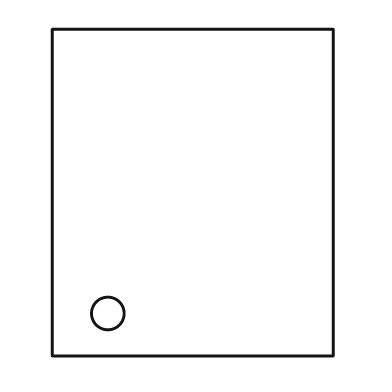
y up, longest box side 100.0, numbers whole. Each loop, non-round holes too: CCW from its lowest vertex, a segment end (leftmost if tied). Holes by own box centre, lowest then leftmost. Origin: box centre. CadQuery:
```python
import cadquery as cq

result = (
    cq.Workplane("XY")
    .moveTo(-43.0, -50.0)
    .lineTo(43.0, -50.0)
    .lineTo(43.0, 50.0)
    .lineTo(-43.0, 50.0)
    .close()
    .moveTo(-26.0, -37.0)
    .circle(5.0)
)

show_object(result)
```